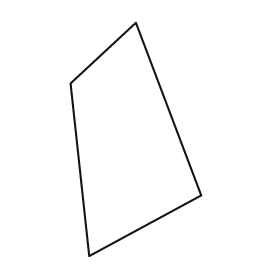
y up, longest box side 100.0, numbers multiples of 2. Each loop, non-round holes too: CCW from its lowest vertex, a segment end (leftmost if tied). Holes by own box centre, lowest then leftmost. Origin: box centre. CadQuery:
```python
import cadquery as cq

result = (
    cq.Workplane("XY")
    .moveTo(-20.0, -50.0)
    .lineTo(28.0, -24.0)
    .lineTo(0.0, 50.0)
    .lineTo(-28.0, 24.0)
    .close()
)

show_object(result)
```